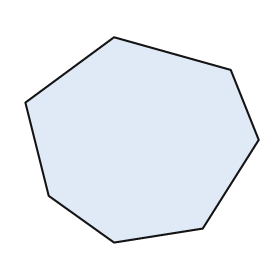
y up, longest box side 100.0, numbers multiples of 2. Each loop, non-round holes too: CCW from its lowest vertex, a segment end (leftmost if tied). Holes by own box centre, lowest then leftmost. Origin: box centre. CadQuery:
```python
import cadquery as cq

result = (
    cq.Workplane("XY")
    .moveTo(-12.0, -44.0)
    .lineTo(26.0, -38.0)
    .lineTo(50.0, 0.0)
    .lineTo(38.0, 30.0)
    .lineTo(-12.0, 44.0)
    .lineTo(-50.0, 16.0)
    .lineTo(-40.0, -24.0)
    .close()
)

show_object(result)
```